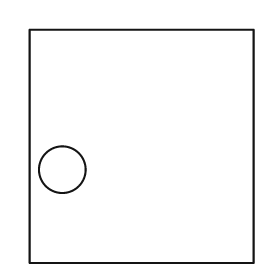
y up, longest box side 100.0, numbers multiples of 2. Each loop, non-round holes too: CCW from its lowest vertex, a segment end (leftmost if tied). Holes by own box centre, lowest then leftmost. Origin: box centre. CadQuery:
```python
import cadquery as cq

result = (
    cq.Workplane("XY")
    .moveTo(-48.0, -50.0)
    .lineTo(48.0, -50.0)
    .lineTo(48.0, 50.0)
    .lineTo(-48.0, 50.0)
    .close()
    .moveTo(-34.0, -10.0)
    .circle(10.0)
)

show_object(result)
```